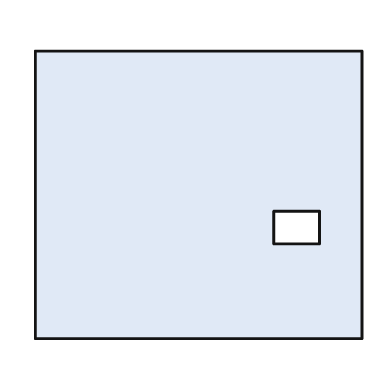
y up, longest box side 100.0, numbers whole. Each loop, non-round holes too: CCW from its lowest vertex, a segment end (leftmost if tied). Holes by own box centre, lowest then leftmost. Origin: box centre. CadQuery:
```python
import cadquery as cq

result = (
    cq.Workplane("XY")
    .moveTo(-50.0, -44.0)
    .lineTo(50.0, -44.0)
    .lineTo(50.0, 44.0)
    .lineTo(-50.0, 44.0)
    .close()
    .moveTo(23.0, -15.0)
    .lineTo(37.0, -15.0)
    .lineTo(37.0, -5.0)
    .lineTo(23.0, -5.0)
    .close()
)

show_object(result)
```